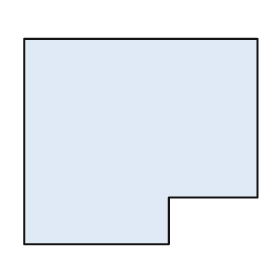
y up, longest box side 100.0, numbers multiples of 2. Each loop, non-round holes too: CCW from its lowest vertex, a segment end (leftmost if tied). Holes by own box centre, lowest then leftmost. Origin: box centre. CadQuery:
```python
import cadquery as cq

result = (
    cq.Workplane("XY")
    .moveTo(-50.0, -44.0)
    .lineTo(12.0, -44.0)
    .lineTo(12.0, -24.0)
    .lineTo(50.0, -24.0)
    .lineTo(50.0, 44.0)
    .lineTo(-50.0, 44.0)
    .close()
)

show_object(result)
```